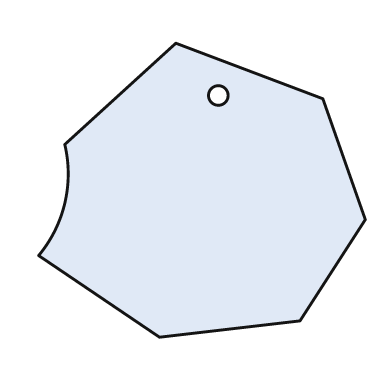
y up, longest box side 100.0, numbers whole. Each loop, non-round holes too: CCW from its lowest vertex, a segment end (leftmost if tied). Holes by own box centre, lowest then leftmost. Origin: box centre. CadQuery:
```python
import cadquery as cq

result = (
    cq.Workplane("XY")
    .moveTo(-13.0, -45.0)
    .lineTo(30.0, -40.0)
    .lineTo(50.0, -9.0)
    .lineTo(37.0, 28.0)
    .lineTo(-8.0, 45.0)
    .lineTo(-42.0, 14.0)
    .threePointArc((-42.0, -4.0), (-50.0, -20.0))
    .close()
    .moveTo(5.0, 29.0)
    .circle(3.0)
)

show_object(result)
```